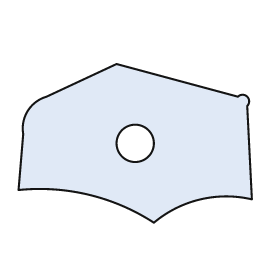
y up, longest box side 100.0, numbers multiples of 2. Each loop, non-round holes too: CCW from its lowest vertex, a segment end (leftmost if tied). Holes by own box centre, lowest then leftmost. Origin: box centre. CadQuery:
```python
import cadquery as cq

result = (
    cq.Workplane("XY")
    .moveTo(8.0, -34.0)
    .threePointArc((28.0, -24.0), (50.0, -24.0))
    .lineTo(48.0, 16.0)
    .threePointArc((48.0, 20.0), (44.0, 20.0))
    .lineTo(-8.0, 34.0)
    .lineTo(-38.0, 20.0)
    .threePointArc((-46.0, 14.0), (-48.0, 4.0))
    .lineTo(-50.0, -20.0)
    .threePointArc((-20.0, -22.0), (8.0, -34.0))
    .close()
    .moveTo(0.0, 0.0)
    .circle(8.0)
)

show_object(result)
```